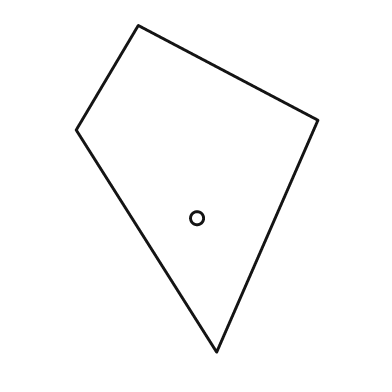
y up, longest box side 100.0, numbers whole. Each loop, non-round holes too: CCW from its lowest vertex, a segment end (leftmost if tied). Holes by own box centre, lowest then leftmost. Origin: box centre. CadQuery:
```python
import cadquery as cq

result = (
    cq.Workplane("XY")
    .moveTo(6.0, -50.0)
    .lineTo(37.0, 21.0)
    .lineTo(-18.0, 50.0)
    .lineTo(-37.0, 18.0)
    .close()
    .moveTo(0.0, -9.0)
    .circle(2.0)
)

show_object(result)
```